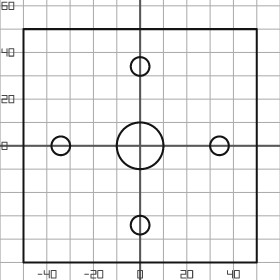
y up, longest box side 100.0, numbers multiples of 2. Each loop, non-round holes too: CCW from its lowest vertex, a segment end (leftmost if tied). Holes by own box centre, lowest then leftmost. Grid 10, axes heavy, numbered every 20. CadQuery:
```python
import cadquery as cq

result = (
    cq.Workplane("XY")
    .moveTo(-50.0, -50.0)
    .lineTo(50.0, -50.0)
    .lineTo(50.0, 50.0)
    .lineTo(-50.0, 50.0)
    .close()
    .moveTo(0.0, -34.0)
    .circle(4.0)
    .moveTo(-34.0, 0.0)
    .circle(4.0)
    .moveTo(0.0, 0.0)
    .circle(10.0)
    .moveTo(34.0, 0.0)
    .circle(4.0)
    .moveTo(0.0, 34.0)
    .circle(4.0)
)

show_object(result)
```